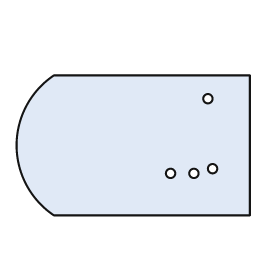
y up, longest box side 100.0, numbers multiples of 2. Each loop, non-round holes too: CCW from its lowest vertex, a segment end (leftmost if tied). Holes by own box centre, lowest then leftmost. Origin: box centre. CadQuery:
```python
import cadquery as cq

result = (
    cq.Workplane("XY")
    .moveTo(-34.0, -30.0)
    .lineTo(50.0, -30.0)
    .lineTo(50.0, 30.0)
    .lineTo(-34.0, 30.0)
    .threePointArc((-50.0, 0.0), (-34.0, -30.0))
    .close()
    .moveTo(16.0, -12.0)
    .circle(2.0)
    .moveTo(26.0, -12.0)
    .circle(2.0)
    .moveTo(34.0, -10.0)
    .circle(2.0)
    .moveTo(32.0, 20.0)
    .circle(2.0)
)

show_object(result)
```